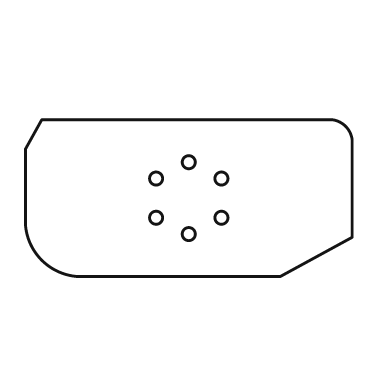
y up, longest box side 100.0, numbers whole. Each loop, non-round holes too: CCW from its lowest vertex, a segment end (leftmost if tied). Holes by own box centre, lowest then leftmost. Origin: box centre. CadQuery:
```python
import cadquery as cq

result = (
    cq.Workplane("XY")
    .moveTo(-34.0, -24.0)
    .lineTo(28.0, -24.0)
    .lineTo(50.0, -12.0)
    .lineTo(50.0, 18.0)
    .threePointArc((48.0, 22.0), (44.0, 24.0))
    .lineTo(-45.0, 24.0)
    .lineTo(-50.0, 15.0)
    .lineTo(-50.0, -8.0)
    .threePointArc((-45.0, -19.0), (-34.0, -24.0))
    .close()
    .moveTo(0.0, -11.0)
    .circle(2.0)
    .moveTo(-10.0, -6.0)
    .circle(2.0)
    .moveTo(10.0, -6.0)
    .circle(2.0)
    .moveTo(-10.0, 6.0)
    .circle(2.0)
    .moveTo(10.0, 6.0)
    .circle(2.0)
    .moveTo(0.0, 11.0)
    .circle(2.0)
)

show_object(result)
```